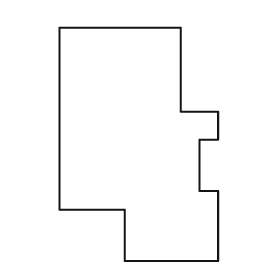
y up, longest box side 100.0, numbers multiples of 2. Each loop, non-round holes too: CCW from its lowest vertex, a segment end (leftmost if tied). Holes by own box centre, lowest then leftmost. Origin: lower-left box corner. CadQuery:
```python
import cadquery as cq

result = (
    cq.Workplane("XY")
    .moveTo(28.0, 0.0)
    .lineTo(68.0, 0.0)
    .lineTo(68.0, 30.0)
    .lineTo(60.0, 30.0)
    .lineTo(60.0, 52.0)
    .lineTo(68.0, 52.0)
    .lineTo(68.0, 64.0)
    .lineTo(52.0, 64.0)
    .lineTo(52.0, 100.0)
    .lineTo(0.0, 100.0)
    .lineTo(0.0, 22.0)
    .lineTo(28.0, 22.0)
    .close()
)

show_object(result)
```